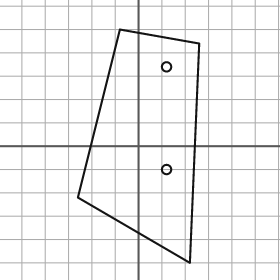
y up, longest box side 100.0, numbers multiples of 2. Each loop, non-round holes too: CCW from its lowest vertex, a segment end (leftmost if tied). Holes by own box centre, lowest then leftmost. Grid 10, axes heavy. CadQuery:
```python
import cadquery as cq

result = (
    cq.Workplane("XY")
    .moveTo(22.0, -50.0)
    .lineTo(26.0, 44.0)
    .lineTo(-8.0, 50.0)
    .lineTo(-26.0, -22.0)
    .close()
    .moveTo(12.0, -10.0)
    .circle(2.0)
    .moveTo(12.0, 34.0)
    .circle(2.0)
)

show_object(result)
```